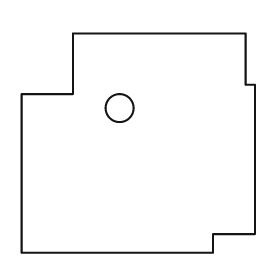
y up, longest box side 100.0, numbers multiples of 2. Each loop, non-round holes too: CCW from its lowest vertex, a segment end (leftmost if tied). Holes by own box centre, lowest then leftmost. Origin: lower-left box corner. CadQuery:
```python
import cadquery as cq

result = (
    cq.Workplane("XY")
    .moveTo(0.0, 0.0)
    .lineTo(82.0, 0.0)
    .lineTo(82.0, 8.0)
    .lineTo(100.0, 8.0)
    .lineTo(100.0, 72.0)
    .lineTo(96.0, 72.0)
    .lineTo(96.0, 94.0)
    .lineTo(22.0, 94.0)
    .lineTo(22.0, 68.0)
    .lineTo(0.0, 68.0)
    .close()
    .moveTo(42.0, 62.0)
    .circle(6.0)
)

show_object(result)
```